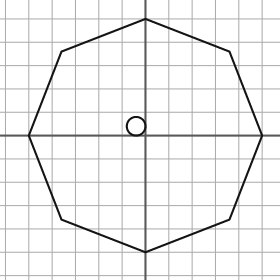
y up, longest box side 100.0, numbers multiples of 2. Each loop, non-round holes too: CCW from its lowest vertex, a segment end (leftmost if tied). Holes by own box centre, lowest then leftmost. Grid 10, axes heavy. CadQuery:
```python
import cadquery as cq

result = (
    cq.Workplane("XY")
    .moveTo(0.0, -50.0)
    .lineTo(36.0, -36.0)
    .lineTo(50.0, 0.0)
    .lineTo(36.0, 36.0)
    .lineTo(0.0, 50.0)
    .lineTo(-36.0, 36.0)
    .lineTo(-50.0, 0.0)
    .lineTo(-36.0, -36.0)
    .close()
    .moveTo(-4.0, 4.0)
    .circle(4.0)
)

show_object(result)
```